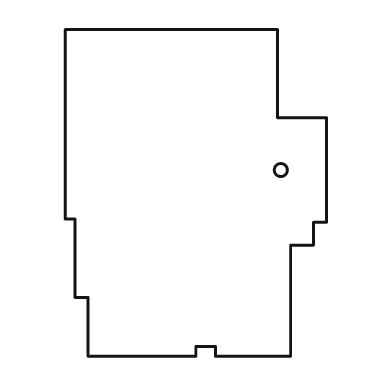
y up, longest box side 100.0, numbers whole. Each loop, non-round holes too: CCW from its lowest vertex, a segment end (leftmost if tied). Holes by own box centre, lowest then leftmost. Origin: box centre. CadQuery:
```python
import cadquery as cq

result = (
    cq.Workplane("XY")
    .moveTo(-33.0, -50.0)
    .lineTo(0.0, -50.0)
    .lineTo(0.0, -47.0)
    .lineTo(6.0, -47.0)
    .lineTo(6.0, -50.0)
    .lineTo(29.0, -50.0)
    .lineTo(29.0, -16.0)
    .lineTo(36.0, -16.0)
    .lineTo(36.0, -9.0)
    .lineTo(40.0, -9.0)
    .lineTo(40.0, 23.0)
    .lineTo(25.0, 23.0)
    .lineTo(25.0, 50.0)
    .lineTo(-40.0, 50.0)
    .lineTo(-40.0, -8.0)
    .lineTo(-37.0, -8.0)
    .lineTo(-37.0, -32.0)
    .lineTo(-33.0, -32.0)
    .close()
    .moveTo(26.0, 7.0)
    .circle(2.0)
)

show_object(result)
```